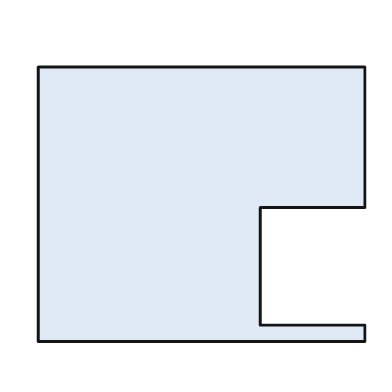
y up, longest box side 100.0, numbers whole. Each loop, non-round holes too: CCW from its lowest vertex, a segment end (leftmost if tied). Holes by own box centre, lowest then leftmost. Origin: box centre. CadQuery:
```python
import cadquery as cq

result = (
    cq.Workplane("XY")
    .moveTo(-50.0, -42.0)
    .lineTo(50.0, -42.0)
    .lineTo(50.0, -37.0)
    .lineTo(18.0, -37.0)
    .lineTo(18.0, -1.0)
    .lineTo(50.0, -1.0)
    .lineTo(50.0, 42.0)
    .lineTo(-50.0, 42.0)
    .close()
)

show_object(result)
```